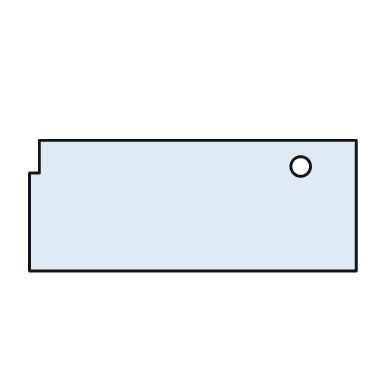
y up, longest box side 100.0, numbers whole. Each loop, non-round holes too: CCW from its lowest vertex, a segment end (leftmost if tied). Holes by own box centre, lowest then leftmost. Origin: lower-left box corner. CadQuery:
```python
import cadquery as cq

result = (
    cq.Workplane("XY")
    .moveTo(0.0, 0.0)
    .lineTo(100.0, 0.0)
    .lineTo(100.0, 40.0)
    .lineTo(3.0, 40.0)
    .lineTo(3.0, 30.0)
    .lineTo(0.0, 30.0)
    .close()
    .moveTo(83.0, 32.0)
    .circle(3.0)
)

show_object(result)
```